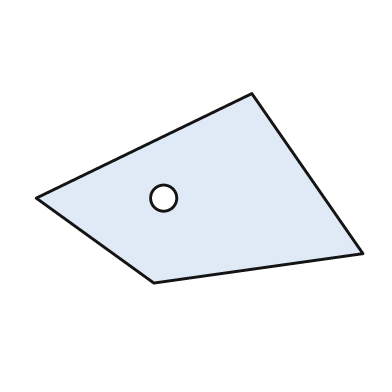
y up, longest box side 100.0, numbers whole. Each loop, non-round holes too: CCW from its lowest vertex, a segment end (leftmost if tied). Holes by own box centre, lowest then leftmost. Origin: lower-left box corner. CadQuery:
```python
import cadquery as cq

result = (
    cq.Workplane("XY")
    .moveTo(36.0, 0.0)
    .lineTo(100.0, 9.0)
    .lineTo(66.0, 58.0)
    .lineTo(0.0, 26.0)
    .close()
    .moveTo(39.0, 26.0)
    .circle(4.0)
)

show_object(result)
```